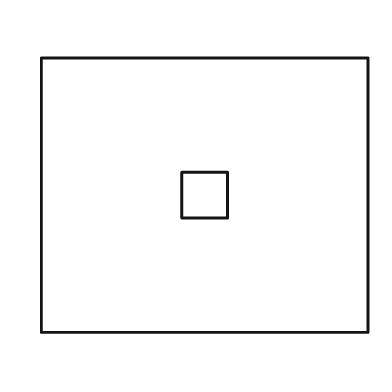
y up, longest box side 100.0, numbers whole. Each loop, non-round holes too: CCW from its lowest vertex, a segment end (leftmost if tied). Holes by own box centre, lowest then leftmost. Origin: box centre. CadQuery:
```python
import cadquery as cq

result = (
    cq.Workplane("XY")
    .moveTo(-50.0, -42.0)
    .lineTo(50.0, -42.0)
    .lineTo(50.0, 42.0)
    .lineTo(-50.0, 42.0)
    .close()
    .moveTo(-7.0, -7.0)
    .lineTo(7.0, -7.0)
    .lineTo(7.0, 7.0)
    .lineTo(-7.0, 7.0)
    .close()
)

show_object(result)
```